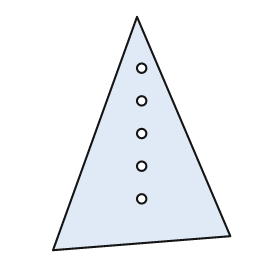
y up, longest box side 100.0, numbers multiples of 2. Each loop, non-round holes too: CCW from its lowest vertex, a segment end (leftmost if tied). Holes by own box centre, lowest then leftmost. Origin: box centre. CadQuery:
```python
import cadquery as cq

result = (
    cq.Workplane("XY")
    .moveTo(-38.0, -50.0)
    .lineTo(38.0, -44.0)
    .lineTo(-2.0, 50.0)
    .close()
    .moveTo(0.0, -28.0)
    .circle(2.0)
    .moveTo(0.0, -14.0)
    .circle(2.0)
    .moveTo(0.0, 0.0)
    .circle(2.0)
    .moveTo(0.0, 14.0)
    .circle(2.0)
    .moveTo(0.0, 28.0)
    .circle(2.0)
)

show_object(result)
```